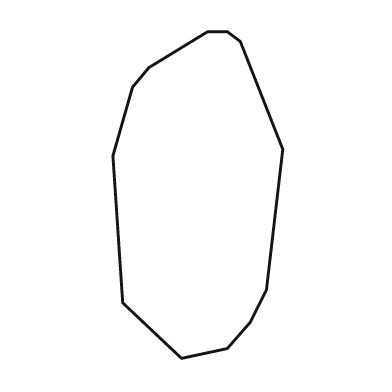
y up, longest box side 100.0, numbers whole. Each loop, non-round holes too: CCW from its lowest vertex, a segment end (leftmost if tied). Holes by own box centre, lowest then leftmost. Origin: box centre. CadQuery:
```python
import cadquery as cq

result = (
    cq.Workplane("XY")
    .moveTo(-5.0, -50.0)
    .lineTo(9.0, -47.0)
    .lineTo(16.0, -39.0)
    .lineTo(21.0, -29.0)
    .lineTo(26.0, 14.0)
    .lineTo(13.0, 47.0)
    .lineTo(9.0, 50.0)
    .lineTo(3.0, 50.0)
    .lineTo(-15.0, 39.0)
    .lineTo(-20.0, 33.0)
    .lineTo(-26.0, 12.0)
    .lineTo(-23.0, -33.0)
    .close()
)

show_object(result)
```